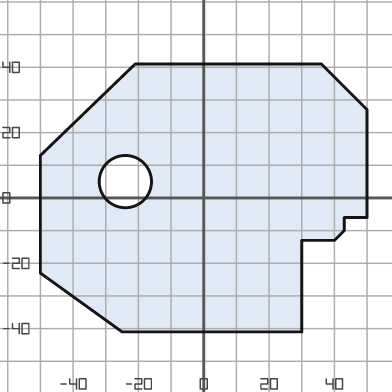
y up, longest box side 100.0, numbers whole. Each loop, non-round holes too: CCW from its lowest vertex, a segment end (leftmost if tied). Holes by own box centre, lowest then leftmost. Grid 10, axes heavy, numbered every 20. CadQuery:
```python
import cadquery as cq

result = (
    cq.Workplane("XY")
    .moveTo(-25.0, -41.0)
    .lineTo(30.0, -41.0)
    .lineTo(30.0, -13.0)
    .lineTo(40.0, -13.0)
    .lineTo(43.0, -10.0)
    .lineTo(43.0, -6.0)
    .lineTo(50.0, -6.0)
    .lineTo(50.0, 27.0)
    .lineTo(36.0, 41.0)
    .lineTo(-21.0, 41.0)
    .lineTo(-50.0, 13.0)
    .lineTo(-50.0, -23.0)
    .close()
    .moveTo(-24.0, 5.0)
    .circle(8.0)
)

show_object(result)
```